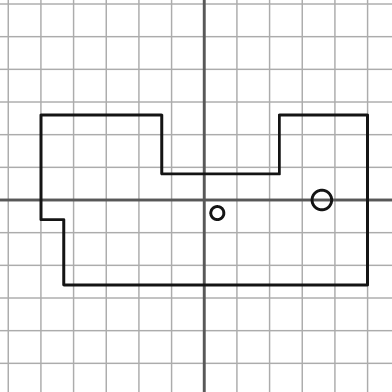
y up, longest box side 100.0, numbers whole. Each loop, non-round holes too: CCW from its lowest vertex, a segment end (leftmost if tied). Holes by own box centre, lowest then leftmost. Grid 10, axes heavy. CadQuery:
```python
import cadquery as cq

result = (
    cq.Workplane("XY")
    .moveTo(-43.0, -26.0)
    .lineTo(50.0, -26.0)
    .lineTo(50.0, 26.0)
    .lineTo(23.0, 26.0)
    .lineTo(23.0, 8.0)
    .lineTo(-13.0, 8.0)
    .lineTo(-13.0, 26.0)
    .lineTo(-50.0, 26.0)
    .lineTo(-50.0, -6.0)
    .lineTo(-43.0, -6.0)
    .close()
    .moveTo(4.0, -4.0)
    .circle(2.0)
    .moveTo(36.0, 0.0)
    .circle(3.0)
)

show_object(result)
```